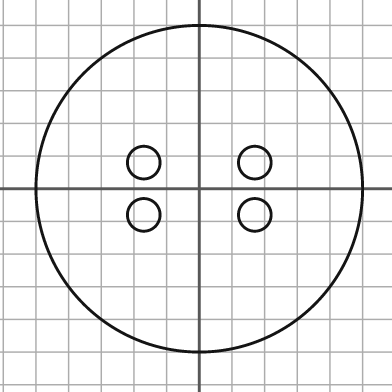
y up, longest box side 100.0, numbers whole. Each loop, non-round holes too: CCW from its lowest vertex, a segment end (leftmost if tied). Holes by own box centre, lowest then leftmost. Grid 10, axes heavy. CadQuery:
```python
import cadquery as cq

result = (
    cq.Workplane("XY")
    .moveTo(0.0, 0.0)
    .circle(50.0)
    .moveTo(-17.0, -8.0)
    .circle(5.0)
    .moveTo(17.0, -8.0)
    .circle(5.0)
    .moveTo(-17.0, 8.0)
    .circle(5.0)
    .moveTo(17.0, 8.0)
    .circle(5.0)
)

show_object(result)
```